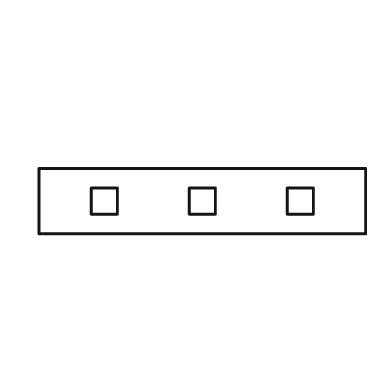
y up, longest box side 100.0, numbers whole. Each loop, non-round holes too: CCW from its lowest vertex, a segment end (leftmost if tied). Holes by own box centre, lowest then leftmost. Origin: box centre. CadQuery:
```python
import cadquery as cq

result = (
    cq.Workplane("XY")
    .moveTo(-50.0, -10.0)
    .lineTo(50.0, -10.0)
    .lineTo(50.0, 10.0)
    .lineTo(-50.0, 10.0)
    .close()
    .moveTo(-34.0, -4.0)
    .lineTo(-26.0, -4.0)
    .lineTo(-26.0, 4.0)
    .lineTo(-34.0, 4.0)
    .close()
    .moveTo(-4.0, -4.0)
    .lineTo(4.0, -4.0)
    .lineTo(4.0, 4.0)
    .lineTo(-4.0, 4.0)
    .close()
    .moveTo(26.0, -4.0)
    .lineTo(34.0, -4.0)
    .lineTo(34.0, 4.0)
    .lineTo(26.0, 4.0)
    .close()
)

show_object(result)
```